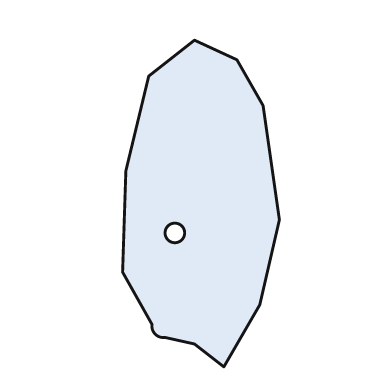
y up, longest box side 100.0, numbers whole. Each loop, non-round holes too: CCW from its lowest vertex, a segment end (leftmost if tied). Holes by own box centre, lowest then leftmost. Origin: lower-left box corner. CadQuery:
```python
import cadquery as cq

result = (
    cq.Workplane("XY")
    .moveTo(31.0, 0.0)
    .lineTo(42.0, 19.0)
    .lineTo(48.0, 45.0)
    .lineTo(43.0, 80.0)
    .lineTo(35.0, 94.0)
    .lineTo(22.0, 100.0)
    .lineTo(8.0, 89.0)
    .lineTo(1.0, 60.0)
    .lineTo(0.0, 29.0)
    .lineTo(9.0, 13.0)
    .threePointArc((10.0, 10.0), (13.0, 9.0))
    .lineTo(22.0, 7.0)
    .close()
    .moveTo(16.0, 41.0)
    .circle(3.0)
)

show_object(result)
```